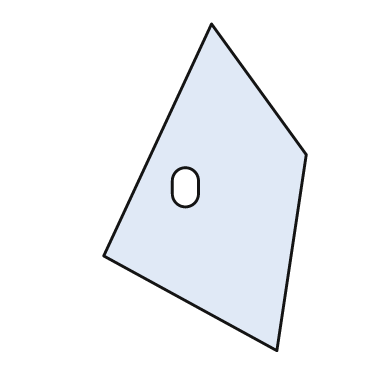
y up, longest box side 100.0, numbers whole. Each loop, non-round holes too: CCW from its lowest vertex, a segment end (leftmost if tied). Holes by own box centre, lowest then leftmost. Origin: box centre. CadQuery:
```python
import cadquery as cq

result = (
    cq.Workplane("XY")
    .moveTo(22.0, -50.0)
    .lineTo(31.0, 10.0)
    .lineTo(2.0, 50.0)
    .lineTo(-31.0, -21.0)
    .close()
    .moveTo(-10.0, -2.0)
    .threePointArc((-6.0, -6.0), (-2.0, -2.0))
    .lineTo(-2.0, 2.0)
    .threePointArc((-6.0, 6.0), (-10.0, 2.0))
    .close()
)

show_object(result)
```